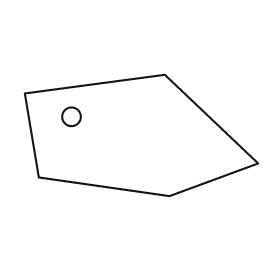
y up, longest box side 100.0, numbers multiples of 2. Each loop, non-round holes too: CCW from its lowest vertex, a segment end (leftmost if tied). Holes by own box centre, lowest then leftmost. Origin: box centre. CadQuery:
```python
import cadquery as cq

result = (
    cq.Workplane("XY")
    .moveTo(12.0, -26.0)
    .lineTo(50.0, -12.0)
    .lineTo(10.0, 26.0)
    .lineTo(-50.0, 18.0)
    .lineTo(-44.0, -18.0)
    .close()
    .moveTo(-30.0, 8.0)
    .circle(4.0)
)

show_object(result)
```